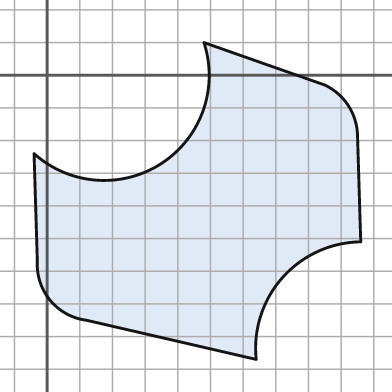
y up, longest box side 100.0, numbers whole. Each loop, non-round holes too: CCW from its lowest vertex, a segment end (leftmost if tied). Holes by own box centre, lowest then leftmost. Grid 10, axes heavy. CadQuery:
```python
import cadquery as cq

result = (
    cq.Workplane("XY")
    .moveTo(64.0, -87.0)
    .threePointArc((72.0, -62.0), (96.0, -51.0))
    .lineTo(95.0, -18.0)
    .threePointArc((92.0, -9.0), (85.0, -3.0))
    .lineTo(48.0, 10.0)
    .threePointArc((35.0, -27.0), (-4.0, -24.0))
    .lineTo(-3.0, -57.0)
    .threePointArc((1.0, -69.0), (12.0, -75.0))
    .close()
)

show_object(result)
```